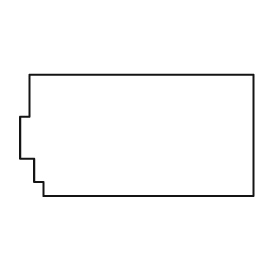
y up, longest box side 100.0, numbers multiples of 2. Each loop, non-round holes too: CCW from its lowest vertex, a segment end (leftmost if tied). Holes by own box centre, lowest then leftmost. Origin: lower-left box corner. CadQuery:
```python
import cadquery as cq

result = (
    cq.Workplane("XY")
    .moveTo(10.0, 0.0)
    .lineTo(100.0, 0.0)
    .lineTo(100.0, 52.0)
    .lineTo(4.0, 52.0)
    .lineTo(4.0, 34.0)
    .lineTo(0.0, 34.0)
    .lineTo(0.0, 16.0)
    .lineTo(6.0, 16.0)
    .lineTo(6.0, 6.0)
    .lineTo(10.0, 6.0)
    .close()
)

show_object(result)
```